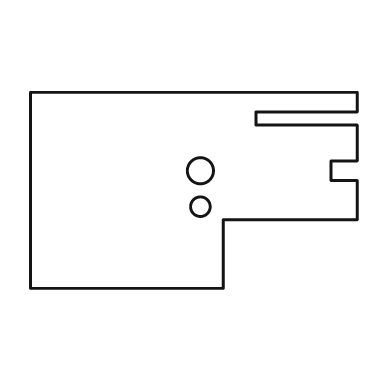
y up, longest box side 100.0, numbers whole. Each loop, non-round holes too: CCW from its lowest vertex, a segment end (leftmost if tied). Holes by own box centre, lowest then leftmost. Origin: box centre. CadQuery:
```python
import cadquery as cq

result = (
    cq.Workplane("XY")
    .moveTo(-50.0, -30.0)
    .lineTo(9.0, -30.0)
    .lineTo(9.0, -9.0)
    .lineTo(50.0, -9.0)
    .lineTo(50.0, 3.0)
    .lineTo(42.0, 3.0)
    .lineTo(42.0, 9.0)
    .lineTo(50.0, 9.0)
    .lineTo(50.0, 20.0)
    .lineTo(19.0, 20.0)
    .lineTo(19.0, 24.0)
    .lineTo(50.0, 24.0)
    .lineTo(50.0, 30.0)
    .lineTo(-50.0, 30.0)
    .close()
    .moveTo(2.0, -5.0)
    .circle(3.0)
    .moveTo(2.0, 6.0)
    .circle(4.0)
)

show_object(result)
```